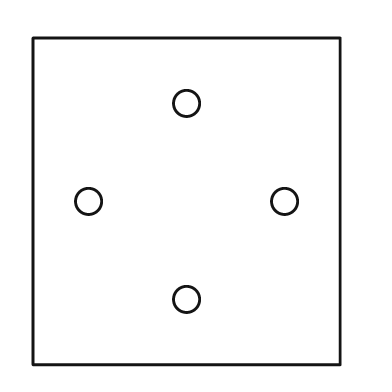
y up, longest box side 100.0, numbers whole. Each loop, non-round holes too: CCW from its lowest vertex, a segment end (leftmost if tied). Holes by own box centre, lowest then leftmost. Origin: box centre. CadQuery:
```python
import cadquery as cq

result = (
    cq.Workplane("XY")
    .moveTo(-47.0, -50.0)
    .lineTo(47.0, -50.0)
    .lineTo(47.0, 50.0)
    .lineTo(-47.0, 50.0)
    .close()
    .moveTo(0.0, -30.0)
    .circle(4.0)
    .moveTo(-30.0, 0.0)
    .circle(4.0)
    .moveTo(30.0, 0.0)
    .circle(4.0)
    .moveTo(0.0, 30.0)
    .circle(4.0)
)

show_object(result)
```